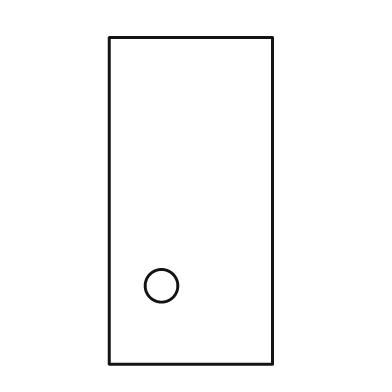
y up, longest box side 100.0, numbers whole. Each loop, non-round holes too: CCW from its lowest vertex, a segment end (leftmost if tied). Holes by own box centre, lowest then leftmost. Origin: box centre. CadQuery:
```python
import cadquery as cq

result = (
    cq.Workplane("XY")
    .moveTo(-25.0, -50.0)
    .lineTo(25.0, -50.0)
    .lineTo(25.0, 50.0)
    .lineTo(-25.0, 50.0)
    .close()
    .moveTo(-9.0, -26.0)
    .circle(5.0)
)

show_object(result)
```